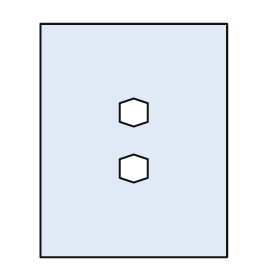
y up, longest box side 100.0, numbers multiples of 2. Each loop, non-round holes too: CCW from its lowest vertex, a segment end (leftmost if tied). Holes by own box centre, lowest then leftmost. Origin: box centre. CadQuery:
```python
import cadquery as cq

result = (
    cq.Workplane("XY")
    .moveTo(-40.0, -50.0)
    .lineTo(40.0, -50.0)
    .lineTo(40.0, 50.0)
    .lineTo(-40.0, 50.0)
    .close()
    .moveTo(0.0, -18.0)
    .lineTo(6.0, -16.0)
    .lineTo(6.0, -8.0)
    .lineTo(0.0, -6.0)
    .lineTo(-6.0, -8.0)
    .lineTo(-6.0, -16.0)
    .close()
    .moveTo(0.0, 6.0)
    .lineTo(6.0, 8.0)
    .lineTo(6.0, 16.0)
    .lineTo(0.0, 18.0)
    .lineTo(-6.0, 16.0)
    .lineTo(-6.0, 8.0)
    .close()
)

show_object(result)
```